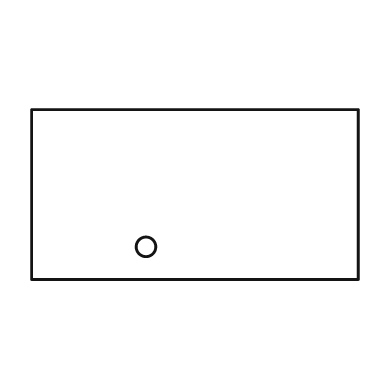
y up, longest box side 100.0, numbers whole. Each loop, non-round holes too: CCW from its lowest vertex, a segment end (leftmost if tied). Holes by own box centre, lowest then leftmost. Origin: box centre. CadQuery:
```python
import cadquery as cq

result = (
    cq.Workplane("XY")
    .moveTo(-50.0, -26.0)
    .lineTo(50.0, -26.0)
    .lineTo(50.0, 26.0)
    .lineTo(-50.0, 26.0)
    .close()
    .moveTo(-15.0, -16.0)
    .circle(3.0)
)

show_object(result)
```